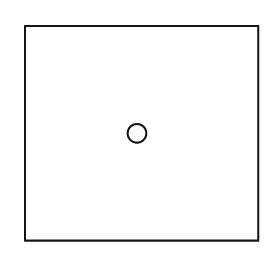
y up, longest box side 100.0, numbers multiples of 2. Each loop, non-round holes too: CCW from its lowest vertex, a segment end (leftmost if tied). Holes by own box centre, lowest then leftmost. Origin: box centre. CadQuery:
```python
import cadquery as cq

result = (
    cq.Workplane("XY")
    .moveTo(-50.0, -46.0)
    .lineTo(50.0, -46.0)
    .lineTo(50.0, 46.0)
    .lineTo(-50.0, 46.0)
    .close()
    .moveTo(-2.0, 0.0)
    .circle(4.0)
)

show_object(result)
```